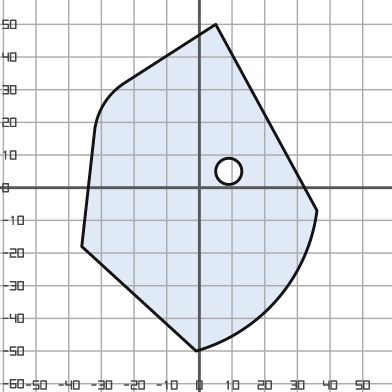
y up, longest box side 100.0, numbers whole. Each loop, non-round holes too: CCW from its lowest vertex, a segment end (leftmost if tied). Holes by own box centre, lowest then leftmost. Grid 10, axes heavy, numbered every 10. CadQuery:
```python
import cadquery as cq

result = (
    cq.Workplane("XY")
    .moveTo(-1.0, -50.0)
    .threePointArc((24.0, -34.0), (36.0, -7.0))
    .lineTo(5.0, 50.0)
    .lineTo(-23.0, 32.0)
    .threePointArc((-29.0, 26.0), (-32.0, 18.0))
    .lineTo(-36.0, -18.0)
    .close()
    .moveTo(9.0, 5.0)
    .circle(4.0)
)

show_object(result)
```